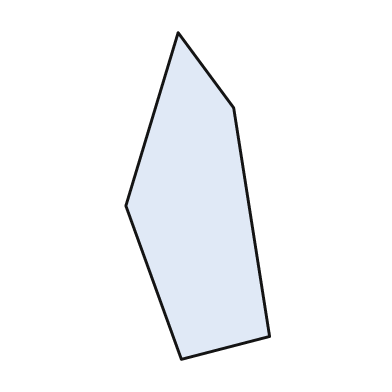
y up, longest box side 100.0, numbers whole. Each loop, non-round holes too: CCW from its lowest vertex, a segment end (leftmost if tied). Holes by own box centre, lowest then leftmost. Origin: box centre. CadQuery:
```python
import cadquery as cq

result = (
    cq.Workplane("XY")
    .moveTo(-5.0, -50.0)
    .lineTo(22.0, -43.0)
    .lineTo(11.0, 27.0)
    .lineTo(-6.0, 50.0)
    .lineTo(-22.0, -3.0)
    .close()
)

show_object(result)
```